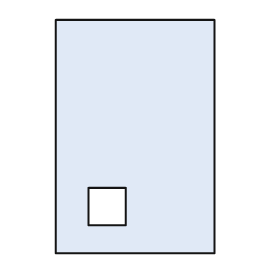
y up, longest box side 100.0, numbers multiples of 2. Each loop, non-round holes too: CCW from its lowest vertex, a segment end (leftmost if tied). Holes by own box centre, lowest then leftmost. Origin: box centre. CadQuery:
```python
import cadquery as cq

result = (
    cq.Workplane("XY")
    .moveTo(-34.0, -50.0)
    .lineTo(34.0, -50.0)
    .lineTo(34.0, 50.0)
    .lineTo(-34.0, 50.0)
    .close()
    .moveTo(-20.0, -38.0)
    .lineTo(-4.0, -38.0)
    .lineTo(-4.0, -22.0)
    .lineTo(-20.0, -22.0)
    .close()
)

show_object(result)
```